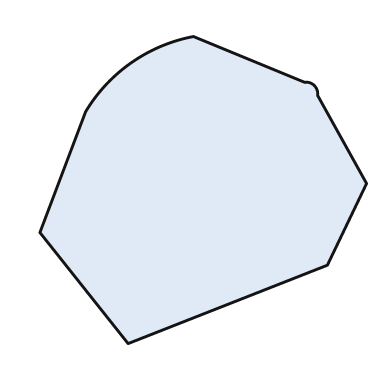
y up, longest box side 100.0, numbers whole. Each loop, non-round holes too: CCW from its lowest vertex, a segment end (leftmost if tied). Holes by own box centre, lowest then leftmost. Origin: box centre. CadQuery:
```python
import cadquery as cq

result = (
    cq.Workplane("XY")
    .moveTo(-23.0, -47.0)
    .lineTo(38.0, -23.0)
    .lineTo(50.0, 2.0)
    .lineTo(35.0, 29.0)
    .threePointArc((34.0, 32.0), (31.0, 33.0))
    .lineTo(-3.0, 47.0)
    .threePointArc((-22.0, 39.0), (-36.0, 24.0))
    .lineTo(-50.0, -13.0)
    .close()
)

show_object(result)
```